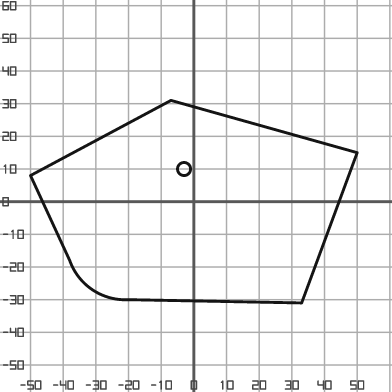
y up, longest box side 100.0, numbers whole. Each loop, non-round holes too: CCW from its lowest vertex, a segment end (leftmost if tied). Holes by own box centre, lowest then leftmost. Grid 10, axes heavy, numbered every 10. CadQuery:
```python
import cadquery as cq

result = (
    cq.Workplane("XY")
    .moveTo(33.0, -31.0)
    .lineTo(50.0, 15.0)
    .lineTo(-7.0, 31.0)
    .lineTo(-50.0, 8.0)
    .lineTo(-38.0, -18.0)
    .threePointArc((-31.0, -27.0), (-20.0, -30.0))
    .close()
    .moveTo(-3.0, 10.0)
    .circle(2.0)
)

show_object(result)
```